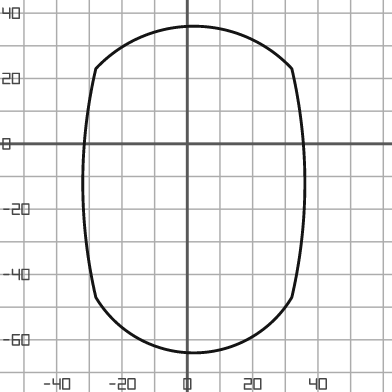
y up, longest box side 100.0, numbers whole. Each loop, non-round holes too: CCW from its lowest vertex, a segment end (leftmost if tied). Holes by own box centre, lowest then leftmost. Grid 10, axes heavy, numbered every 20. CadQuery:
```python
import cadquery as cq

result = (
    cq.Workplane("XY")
    .moveTo(-28.0, -47.0)
    .threePointArc((2.0, -64.0), (32.0, -47.0))
    .threePointArc((36.0, -12.0), (32.0, 23.0))
    .threePointArc((2.0, 36.0), (-28.0, 23.0))
    .threePointArc((-32.0, -12.0), (-28.0, -47.0))
    .close()
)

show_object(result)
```